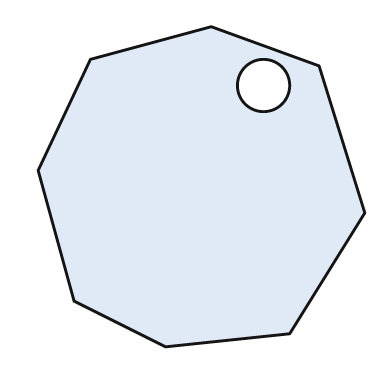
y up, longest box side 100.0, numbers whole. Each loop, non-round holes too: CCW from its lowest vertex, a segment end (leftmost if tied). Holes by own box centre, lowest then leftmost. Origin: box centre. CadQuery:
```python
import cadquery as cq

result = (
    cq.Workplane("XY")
    .moveTo(-11.0, -49.0)
    .lineTo(27.0, -45.0)
    .lineTo(50.0, -8.0)
    .lineTo(36.0, 37.0)
    .lineTo(3.0, 49.0)
    .lineTo(-34.0, 39.0)
    .lineTo(-50.0, 5.0)
    .lineTo(-39.0, -35.0)
    .close()
    .moveTo(19.0, 31.0)
    .circle(8.0)
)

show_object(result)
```